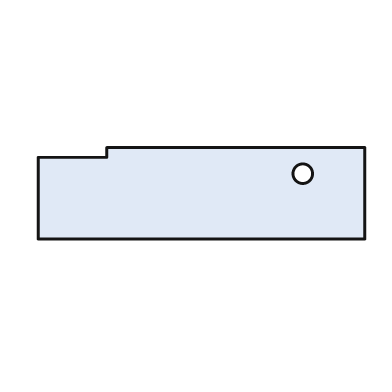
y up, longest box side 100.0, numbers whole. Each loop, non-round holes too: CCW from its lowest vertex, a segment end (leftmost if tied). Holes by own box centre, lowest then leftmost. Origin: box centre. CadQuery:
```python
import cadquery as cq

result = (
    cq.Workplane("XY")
    .moveTo(-50.0, -14.0)
    .lineTo(50.0, -14.0)
    .lineTo(50.0, 14.0)
    .lineTo(-29.0, 14.0)
    .lineTo(-29.0, 11.0)
    .lineTo(-50.0, 11.0)
    .close()
    .moveTo(31.0, 6.0)
    .circle(3.0)
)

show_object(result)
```